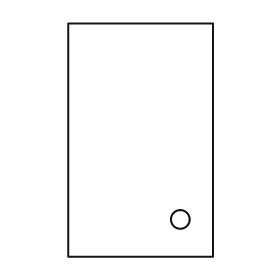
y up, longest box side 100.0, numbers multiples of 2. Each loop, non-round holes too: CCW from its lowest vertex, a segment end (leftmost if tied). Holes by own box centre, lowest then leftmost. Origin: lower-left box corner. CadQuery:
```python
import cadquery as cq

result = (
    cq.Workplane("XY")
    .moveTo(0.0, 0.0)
    .lineTo(62.0, 0.0)
    .lineTo(62.0, 100.0)
    .lineTo(0.0, 100.0)
    .close()
    .moveTo(48.0, 16.0)
    .circle(4.0)
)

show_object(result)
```